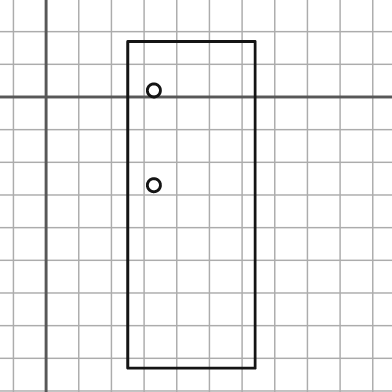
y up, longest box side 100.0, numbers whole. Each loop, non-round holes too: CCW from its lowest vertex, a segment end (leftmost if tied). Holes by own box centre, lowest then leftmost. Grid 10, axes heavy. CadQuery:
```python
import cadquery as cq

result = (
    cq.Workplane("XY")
    .moveTo(25.0, -83.0)
    .lineTo(64.0, -83.0)
    .lineTo(64.0, 17.0)
    .lineTo(25.0, 17.0)
    .close()
    .moveTo(33.0, -27.0)
    .circle(2.0)
    .moveTo(33.0, 2.0)
    .circle(2.0)
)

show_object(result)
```